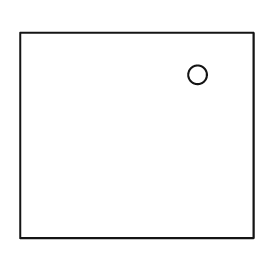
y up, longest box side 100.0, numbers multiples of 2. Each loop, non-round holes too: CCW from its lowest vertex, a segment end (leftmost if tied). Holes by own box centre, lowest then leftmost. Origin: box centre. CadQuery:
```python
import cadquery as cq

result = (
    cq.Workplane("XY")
    .moveTo(-50.0, -44.0)
    .lineTo(50.0, -44.0)
    .lineTo(50.0, 44.0)
    .lineTo(-50.0, 44.0)
    .close()
    .moveTo(26.0, 26.0)
    .circle(4.0)
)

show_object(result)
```